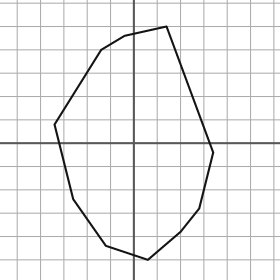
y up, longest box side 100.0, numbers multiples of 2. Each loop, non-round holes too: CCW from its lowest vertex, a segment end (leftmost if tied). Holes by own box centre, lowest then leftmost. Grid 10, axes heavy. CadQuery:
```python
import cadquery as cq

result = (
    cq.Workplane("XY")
    .moveTo(6.0, -50.0)
    .lineTo(20.0, -38.0)
    .lineTo(28.0, -28.0)
    .lineTo(34.0, -4.0)
    .lineTo(14.0, 50.0)
    .lineTo(-4.0, 46.0)
    .lineTo(-14.0, 40.0)
    .lineTo(-34.0, 8.0)
    .lineTo(-26.0, -24.0)
    .lineTo(-12.0, -44.0)
    .close()
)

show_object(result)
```